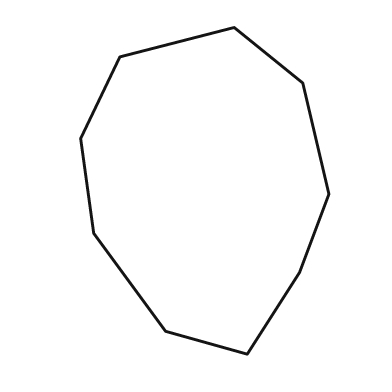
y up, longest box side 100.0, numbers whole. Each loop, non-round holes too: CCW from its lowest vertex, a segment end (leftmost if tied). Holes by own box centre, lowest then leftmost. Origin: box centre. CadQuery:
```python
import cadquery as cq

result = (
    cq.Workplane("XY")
    .moveTo(13.0, -50.0)
    .lineTo(29.0, -25.0)
    .lineTo(38.0, -1.0)
    .lineTo(30.0, 33.0)
    .lineTo(9.0, 50.0)
    .lineTo(-26.0, 41.0)
    .lineTo(-38.0, 16.0)
    .lineTo(-34.0, -13.0)
    .lineTo(-12.0, -43.0)
    .close()
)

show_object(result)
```